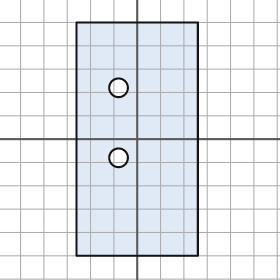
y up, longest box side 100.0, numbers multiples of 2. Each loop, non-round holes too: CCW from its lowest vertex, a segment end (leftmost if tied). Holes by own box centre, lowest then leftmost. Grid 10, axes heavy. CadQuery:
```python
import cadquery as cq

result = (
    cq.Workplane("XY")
    .moveTo(-26.0, -50.0)
    .lineTo(26.0, -50.0)
    .lineTo(26.0, 50.0)
    .lineTo(-26.0, 50.0)
    .close()
    .moveTo(-8.0, -8.0)
    .circle(4.0)
    .moveTo(-8.0, 22.0)
    .circle(4.0)
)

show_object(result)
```